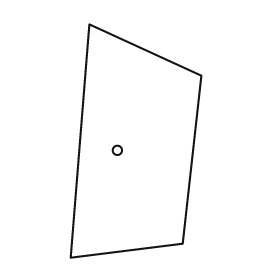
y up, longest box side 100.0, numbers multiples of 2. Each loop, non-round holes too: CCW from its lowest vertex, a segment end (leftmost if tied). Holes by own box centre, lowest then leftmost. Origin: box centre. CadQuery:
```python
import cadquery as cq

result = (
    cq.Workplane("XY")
    .moveTo(-28.0, -50.0)
    .lineTo(20.0, -44.0)
    .lineTo(28.0, 28.0)
    .lineTo(-20.0, 50.0)
    .close()
    .moveTo(-8.0, -4.0)
    .circle(2.0)
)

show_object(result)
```